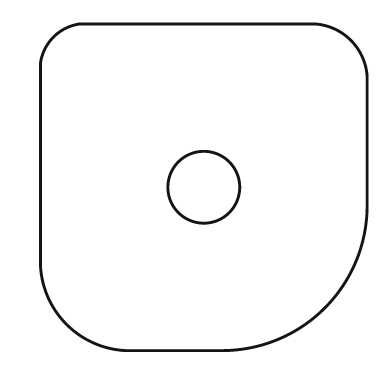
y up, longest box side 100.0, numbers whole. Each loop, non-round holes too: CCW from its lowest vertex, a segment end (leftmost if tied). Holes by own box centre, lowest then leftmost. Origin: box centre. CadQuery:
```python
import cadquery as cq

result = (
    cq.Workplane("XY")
    .moveTo(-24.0, -50.0)
    .lineTo(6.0, -50.0)
    .threePointArc((37.0, -37.0), (50.0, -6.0))
    .lineTo(50.0, 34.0)
    .threePointArc((45.0, 45.0), (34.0, 50.0))
    .lineTo(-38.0, 50.0)
    .threePointArc((-46.0, 46.0), (-50.0, 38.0))
    .lineTo(-50.0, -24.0)
    .threePointArc((-42.0, -42.0), (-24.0, -50.0))
    .close()
    .moveTo(0.0, 0.0)
    .circle(11.0)
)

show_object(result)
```